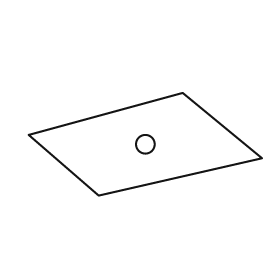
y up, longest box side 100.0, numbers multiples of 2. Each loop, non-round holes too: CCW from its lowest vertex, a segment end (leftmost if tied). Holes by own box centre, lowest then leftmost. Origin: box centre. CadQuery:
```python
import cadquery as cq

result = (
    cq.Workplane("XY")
    .moveTo(-20.0, -22.0)
    .lineTo(50.0, -6.0)
    .lineTo(16.0, 22.0)
    .lineTo(-50.0, 4.0)
    .close()
    .moveTo(0.0, 0.0)
    .circle(4.0)
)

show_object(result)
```